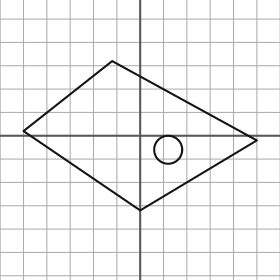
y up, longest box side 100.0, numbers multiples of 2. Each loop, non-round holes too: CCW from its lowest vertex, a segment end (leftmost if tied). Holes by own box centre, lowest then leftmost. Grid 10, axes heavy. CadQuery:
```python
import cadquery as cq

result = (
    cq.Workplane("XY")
    .moveTo(0.0, -32.0)
    .lineTo(50.0, -2.0)
    .lineTo(-12.0, 32.0)
    .lineTo(-50.0, 2.0)
    .close()
    .moveTo(12.0, -6.0)
    .circle(6.0)
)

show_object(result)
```